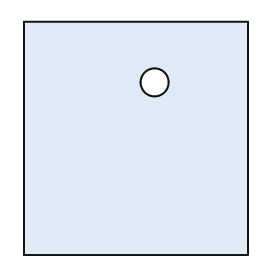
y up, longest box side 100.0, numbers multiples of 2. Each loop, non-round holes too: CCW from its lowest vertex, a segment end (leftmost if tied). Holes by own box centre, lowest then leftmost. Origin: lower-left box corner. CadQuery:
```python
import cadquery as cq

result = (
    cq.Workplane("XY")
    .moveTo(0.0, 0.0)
    .lineTo(96.0, 0.0)
    .lineTo(96.0, 100.0)
    .lineTo(0.0, 100.0)
    .close()
    .moveTo(56.0, 74.0)
    .circle(6.0)
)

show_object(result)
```